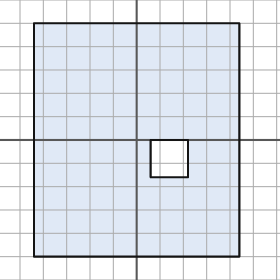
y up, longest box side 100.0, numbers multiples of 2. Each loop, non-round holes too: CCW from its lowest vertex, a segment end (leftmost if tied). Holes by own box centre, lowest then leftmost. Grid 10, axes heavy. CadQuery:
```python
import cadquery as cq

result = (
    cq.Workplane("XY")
    .moveTo(-44.0, -50.0)
    .lineTo(44.0, -50.0)
    .lineTo(44.0, 50.0)
    .lineTo(-44.0, 50.0)
    .close()
    .moveTo(6.0, -16.0)
    .lineTo(22.0, -16.0)
    .lineTo(22.0, 0.0)
    .lineTo(6.0, 0.0)
    .close()
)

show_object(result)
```